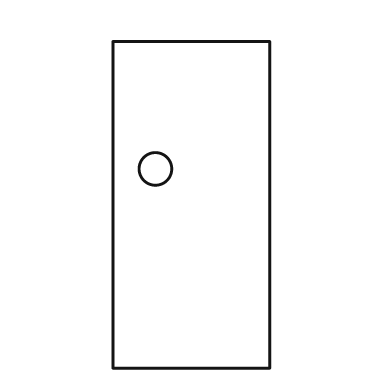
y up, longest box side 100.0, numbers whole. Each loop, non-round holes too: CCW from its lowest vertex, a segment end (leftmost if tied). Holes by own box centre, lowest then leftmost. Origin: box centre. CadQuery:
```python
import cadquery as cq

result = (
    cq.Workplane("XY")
    .moveTo(-24.0, -50.0)
    .lineTo(24.0, -50.0)
    .lineTo(24.0, 50.0)
    .lineTo(-24.0, 50.0)
    .close()
    .moveTo(-11.0, 11.0)
    .circle(5.0)
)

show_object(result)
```